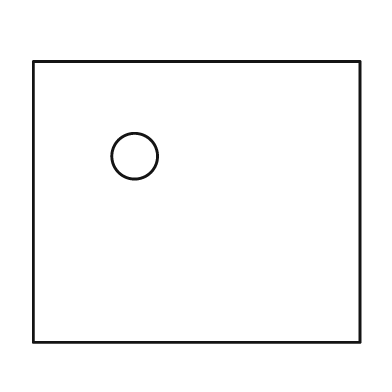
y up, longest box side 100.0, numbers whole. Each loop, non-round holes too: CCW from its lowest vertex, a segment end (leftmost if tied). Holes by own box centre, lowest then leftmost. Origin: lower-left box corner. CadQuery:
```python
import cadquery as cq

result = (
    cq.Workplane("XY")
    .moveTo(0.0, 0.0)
    .lineTo(100.0, 0.0)
    .lineTo(100.0, 86.0)
    .lineTo(0.0, 86.0)
    .close()
    .moveTo(31.0, 57.0)
    .circle(7.0)
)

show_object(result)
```